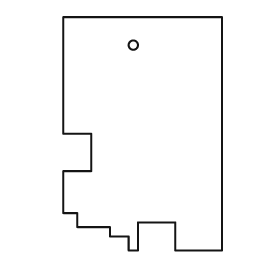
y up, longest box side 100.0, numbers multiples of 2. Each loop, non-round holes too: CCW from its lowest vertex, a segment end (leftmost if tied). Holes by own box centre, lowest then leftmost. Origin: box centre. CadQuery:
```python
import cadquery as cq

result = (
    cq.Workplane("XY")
    .moveTo(-6.0, -50.0)
    .lineTo(-2.0, -50.0)
    .lineTo(-2.0, -38.0)
    .lineTo(14.0, -38.0)
    .lineTo(14.0, -50.0)
    .lineTo(34.0, -50.0)
    .lineTo(34.0, 50.0)
    .lineTo(-34.0, 50.0)
    .lineTo(-34.0, 0.0)
    .lineTo(-22.0, 0.0)
    .lineTo(-22.0, -16.0)
    .lineTo(-34.0, -16.0)
    .lineTo(-34.0, -34.0)
    .lineTo(-28.0, -34.0)
    .lineTo(-28.0, -40.0)
    .lineTo(-14.0, -40.0)
    .lineTo(-14.0, -44.0)
    .lineTo(-6.0, -44.0)
    .close()
    .moveTo(-4.0, 38.0)
    .circle(2.0)
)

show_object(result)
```